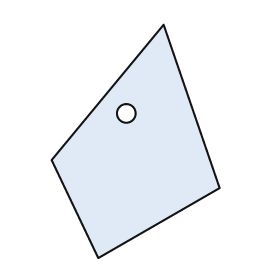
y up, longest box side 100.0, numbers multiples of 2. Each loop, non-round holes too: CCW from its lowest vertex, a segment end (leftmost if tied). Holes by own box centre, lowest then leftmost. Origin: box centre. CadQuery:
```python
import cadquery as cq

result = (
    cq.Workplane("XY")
    .moveTo(-16.0, -50.0)
    .lineTo(36.0, -20.0)
    .lineTo(12.0, 50.0)
    .lineTo(-36.0, -8.0)
    .close()
    .moveTo(-4.0, 12.0)
    .circle(4.0)
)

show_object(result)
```